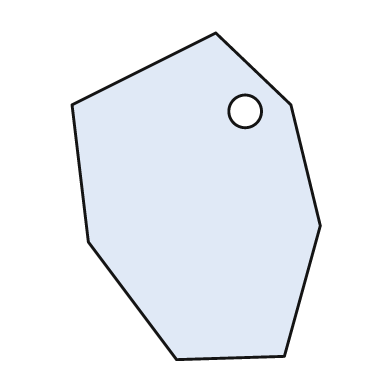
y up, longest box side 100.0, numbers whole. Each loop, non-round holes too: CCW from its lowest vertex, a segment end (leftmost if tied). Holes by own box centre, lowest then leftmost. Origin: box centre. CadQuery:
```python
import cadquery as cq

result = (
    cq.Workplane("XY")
    .moveTo(-6.0, -50.0)
    .lineTo(27.0, -49.0)
    .lineTo(38.0, -9.0)
    .lineTo(29.0, 28.0)
    .lineTo(6.0, 50.0)
    .lineTo(-38.0, 28.0)
    .lineTo(-33.0, -14.0)
    .close()
    .moveTo(15.0, 26.0)
    .circle(5.0)
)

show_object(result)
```